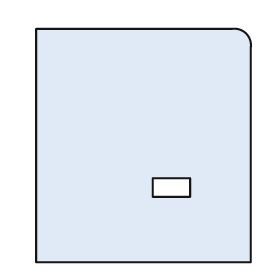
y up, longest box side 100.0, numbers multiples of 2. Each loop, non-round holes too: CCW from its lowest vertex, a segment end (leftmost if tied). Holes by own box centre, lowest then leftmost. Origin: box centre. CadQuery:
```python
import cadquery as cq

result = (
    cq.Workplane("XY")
    .moveTo(-46.0, -50.0)
    .lineTo(46.0, -50.0)
    .lineTo(46.0, 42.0)
    .threePointArc((44.0, 48.0), (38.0, 50.0))
    .lineTo(-46.0, 50.0)
    .close()
    .moveTo(4.0, -22.0)
    .lineTo(20.0, -22.0)
    .lineTo(20.0, -14.0)
    .lineTo(4.0, -14.0)
    .close()
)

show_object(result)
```